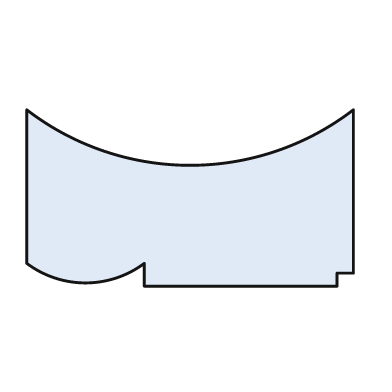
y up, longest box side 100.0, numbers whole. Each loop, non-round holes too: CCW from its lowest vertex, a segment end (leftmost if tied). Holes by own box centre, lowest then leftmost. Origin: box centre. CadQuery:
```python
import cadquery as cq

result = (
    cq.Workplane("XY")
    .moveTo(-14.0, -27.0)
    .lineTo(45.0, -27.0)
    .lineTo(45.0, -23.0)
    .lineTo(50.0, -23.0)
    .lineTo(50.0, 27.0)
    .threePointArc((0.0, 10.0), (-50.0, 27.0))
    .lineTo(-50.0, -20.0)
    .threePointArc((-32.0, -26.0), (-14.0, -20.0))
    .close()
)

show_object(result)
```